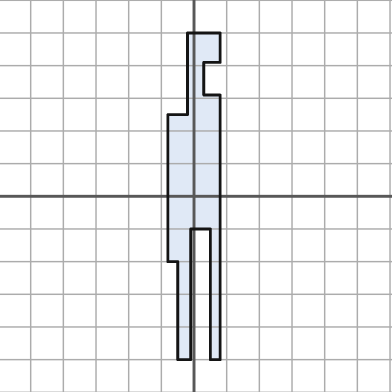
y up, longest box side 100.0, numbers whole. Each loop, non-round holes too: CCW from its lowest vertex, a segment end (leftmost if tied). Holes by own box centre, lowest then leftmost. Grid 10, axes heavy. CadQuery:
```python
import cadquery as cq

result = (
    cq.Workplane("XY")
    .moveTo(-5.0, -50.0)
    .lineTo(-1.0, -50.0)
    .lineTo(-1.0, -10.0)
    .lineTo(5.0, -10.0)
    .lineTo(5.0, -50.0)
    .lineTo(8.0, -50.0)
    .lineTo(8.0, 31.0)
    .lineTo(3.0, 31.0)
    .lineTo(3.0, 41.0)
    .lineTo(8.0, 41.0)
    .lineTo(8.0, 50.0)
    .lineTo(-2.0, 50.0)
    .lineTo(-2.0, 25.0)
    .lineTo(-8.0, 25.0)
    .lineTo(-8.0, -20.0)
    .lineTo(-5.0, -20.0)
    .close()
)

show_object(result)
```